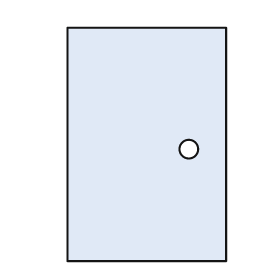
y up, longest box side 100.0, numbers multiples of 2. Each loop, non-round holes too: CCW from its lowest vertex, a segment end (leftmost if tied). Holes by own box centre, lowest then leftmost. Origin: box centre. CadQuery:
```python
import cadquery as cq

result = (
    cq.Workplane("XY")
    .moveTo(-34.0, -50.0)
    .lineTo(34.0, -50.0)
    .lineTo(34.0, 50.0)
    .lineTo(-34.0, 50.0)
    .close()
    .moveTo(18.0, -2.0)
    .circle(4.0)
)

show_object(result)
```